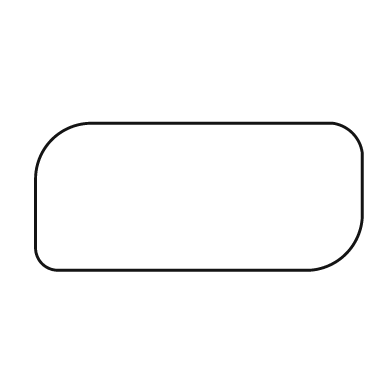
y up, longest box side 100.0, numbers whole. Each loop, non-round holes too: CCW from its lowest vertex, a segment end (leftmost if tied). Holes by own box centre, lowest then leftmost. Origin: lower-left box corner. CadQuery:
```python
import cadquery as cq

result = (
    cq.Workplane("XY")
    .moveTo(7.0, 0.0)
    .lineTo(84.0, 0.0)
    .threePointArc((95.0, 5.0), (100.0, 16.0))
    .lineTo(100.0, 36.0)
    .threePointArc((97.0, 42.0), (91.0, 45.0))
    .lineTo(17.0, 45.0)
    .threePointArc((5.0, 40.0), (0.0, 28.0))
    .lineTo(0.0, 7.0)
    .threePointArc((2.0, 2.0), (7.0, 0.0))
    .close()
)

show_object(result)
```